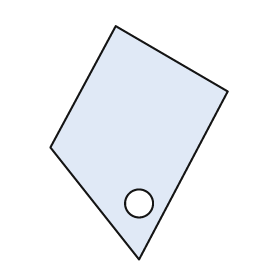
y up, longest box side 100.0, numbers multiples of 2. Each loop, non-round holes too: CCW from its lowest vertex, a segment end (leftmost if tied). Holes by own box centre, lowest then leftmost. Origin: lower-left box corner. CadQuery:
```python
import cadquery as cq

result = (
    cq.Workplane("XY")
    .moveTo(38.0, 0.0)
    .lineTo(76.0, 72.0)
    .lineTo(28.0, 100.0)
    .lineTo(0.0, 48.0)
    .close()
    .moveTo(38.0, 24.0)
    .circle(6.0)
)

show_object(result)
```